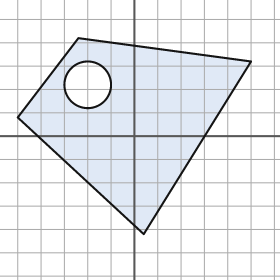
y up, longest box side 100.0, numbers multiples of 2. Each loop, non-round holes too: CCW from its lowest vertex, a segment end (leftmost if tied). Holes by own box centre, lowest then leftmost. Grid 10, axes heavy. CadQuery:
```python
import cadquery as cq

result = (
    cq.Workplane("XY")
    .moveTo(4.0, -42.0)
    .lineTo(50.0, 32.0)
    .lineTo(-24.0, 42.0)
    .lineTo(-50.0, 8.0)
    .close()
    .moveTo(-20.0, 22.0)
    .circle(10.0)
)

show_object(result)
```